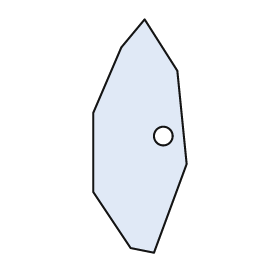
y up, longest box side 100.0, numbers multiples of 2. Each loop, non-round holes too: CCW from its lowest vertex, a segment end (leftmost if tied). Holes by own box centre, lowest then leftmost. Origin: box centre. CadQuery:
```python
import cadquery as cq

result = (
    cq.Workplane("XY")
    .moveTo(6.0, -50.0)
    .lineTo(20.0, -12.0)
    .lineTo(16.0, 28.0)
    .lineTo(2.0, 50.0)
    .lineTo(-8.0, 38.0)
    .lineTo(-20.0, 10.0)
    .lineTo(-20.0, -24.0)
    .lineTo(-4.0, -48.0)
    .close()
    .moveTo(10.0, 0.0)
    .circle(4.0)
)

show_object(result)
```